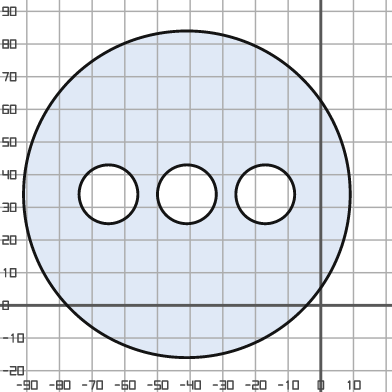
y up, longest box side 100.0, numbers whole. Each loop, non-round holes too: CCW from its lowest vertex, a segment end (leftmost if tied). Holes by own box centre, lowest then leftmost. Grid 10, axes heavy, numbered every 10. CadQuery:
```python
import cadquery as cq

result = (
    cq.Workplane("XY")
    .moveTo(-41.0, 34.0)
    .circle(50.0)
    .moveTo(-65.0, 34.0)
    .circle(9.0)
    .moveTo(-41.0, 34.0)
    .circle(9.0)
    .moveTo(-17.0, 34.0)
    .circle(9.0)
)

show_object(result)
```